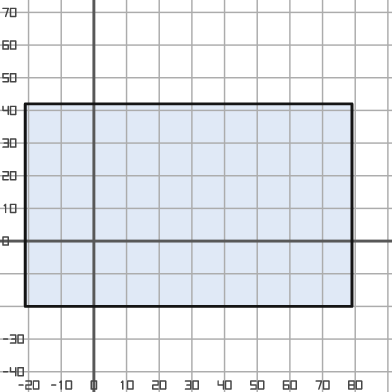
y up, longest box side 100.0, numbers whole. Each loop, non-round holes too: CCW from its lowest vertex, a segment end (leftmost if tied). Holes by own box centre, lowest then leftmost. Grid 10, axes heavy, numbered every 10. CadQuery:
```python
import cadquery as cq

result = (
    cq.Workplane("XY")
    .moveTo(-21.0, -20.0)
    .lineTo(79.0, -20.0)
    .lineTo(79.0, 42.0)
    .lineTo(-21.0, 42.0)
    .close()
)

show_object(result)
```